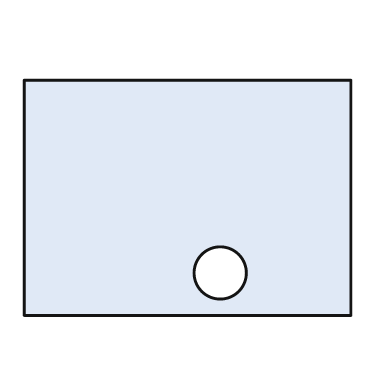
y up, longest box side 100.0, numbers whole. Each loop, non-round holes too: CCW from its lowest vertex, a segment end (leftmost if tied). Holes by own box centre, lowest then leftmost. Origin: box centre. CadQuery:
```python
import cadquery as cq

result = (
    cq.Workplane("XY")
    .moveTo(-50.0, -36.0)
    .lineTo(50.0, -36.0)
    .lineTo(50.0, 36.0)
    .lineTo(-50.0, 36.0)
    .close()
    .moveTo(10.0, -23.0)
    .circle(8.0)
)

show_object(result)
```